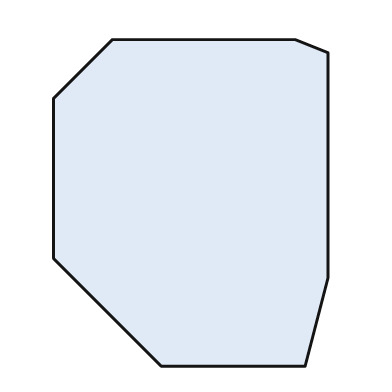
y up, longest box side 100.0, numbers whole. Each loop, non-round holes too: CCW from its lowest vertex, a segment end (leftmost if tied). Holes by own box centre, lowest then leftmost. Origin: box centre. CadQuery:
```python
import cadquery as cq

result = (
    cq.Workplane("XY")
    .moveTo(-9.0, -50.0)
    .lineTo(35.0, -50.0)
    .lineTo(42.0, -23.0)
    .lineTo(42.0, 46.0)
    .lineTo(32.0, 50.0)
    .lineTo(-24.0, 50.0)
    .lineTo(-42.0, 32.0)
    .lineTo(-42.0, -17.0)
    .close()
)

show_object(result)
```